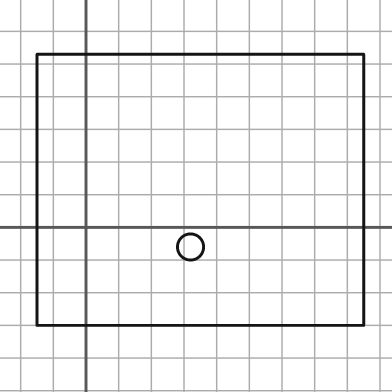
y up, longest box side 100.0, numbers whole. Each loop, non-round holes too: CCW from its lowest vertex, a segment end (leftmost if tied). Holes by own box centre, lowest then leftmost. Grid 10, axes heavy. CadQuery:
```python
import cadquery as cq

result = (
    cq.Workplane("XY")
    .moveTo(-15.0, -30.0)
    .lineTo(85.0, -30.0)
    .lineTo(85.0, 53.0)
    .lineTo(-15.0, 53.0)
    .close()
    .moveTo(32.0, -6.0)
    .circle(4.0)
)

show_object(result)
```